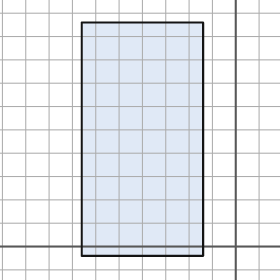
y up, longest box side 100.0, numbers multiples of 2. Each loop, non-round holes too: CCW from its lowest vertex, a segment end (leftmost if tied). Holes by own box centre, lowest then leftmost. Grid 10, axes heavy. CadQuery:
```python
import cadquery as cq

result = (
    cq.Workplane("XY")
    .moveTo(-66.0, -4.0)
    .lineTo(-14.0, -4.0)
    .lineTo(-14.0, 96.0)
    .lineTo(-66.0, 96.0)
    .close()
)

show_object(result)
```